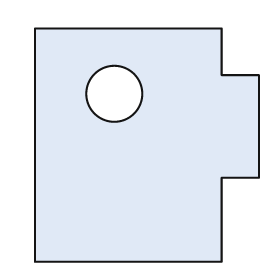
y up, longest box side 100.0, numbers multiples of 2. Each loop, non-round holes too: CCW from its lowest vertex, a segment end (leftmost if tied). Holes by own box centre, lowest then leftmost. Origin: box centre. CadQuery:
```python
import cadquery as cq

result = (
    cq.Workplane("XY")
    .moveTo(-48.0, -50.0)
    .lineTo(32.0, -50.0)
    .lineTo(32.0, -14.0)
    .lineTo(48.0, -14.0)
    .lineTo(48.0, 30.0)
    .lineTo(32.0, 30.0)
    .lineTo(32.0, 50.0)
    .lineTo(-48.0, 50.0)
    .close()
    .moveTo(-14.0, 22.0)
    .circle(12.0)
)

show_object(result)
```